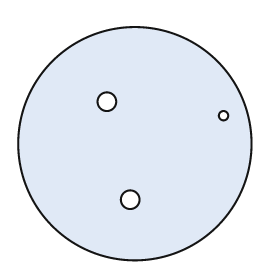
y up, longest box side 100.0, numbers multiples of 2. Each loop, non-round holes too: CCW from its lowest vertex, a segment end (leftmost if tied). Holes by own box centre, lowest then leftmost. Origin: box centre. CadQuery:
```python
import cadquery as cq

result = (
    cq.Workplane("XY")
    .moveTo(0.0, 0.0)
    .circle(50.0)
    .moveTo(-2.0, -24.0)
    .circle(4.0)
    .moveTo(38.0, 12.0)
    .circle(2.0)
    .moveTo(-12.0, 18.0)
    .circle(4.0)
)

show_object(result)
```